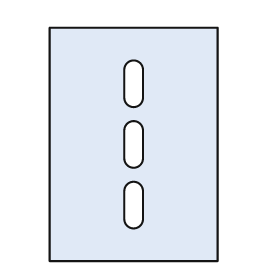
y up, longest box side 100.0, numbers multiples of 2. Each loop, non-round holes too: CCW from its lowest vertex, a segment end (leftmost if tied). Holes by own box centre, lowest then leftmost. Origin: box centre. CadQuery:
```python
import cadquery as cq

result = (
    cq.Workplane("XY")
    .moveTo(-36.0, -50.0)
    .lineTo(36.0, -50.0)
    .lineTo(36.0, 50.0)
    .lineTo(-36.0, 50.0)
    .close()
    .moveTo(-4.0, -32.0)
    .threePointArc((0.0, -36.0), (4.0, -32.0))
    .lineTo(4.0, -20.0)
    .threePointArc((0.0, -16.0), (-4.0, -20.0))
    .close()
    .moveTo(-4.0, -6.0)
    .threePointArc((0.0, -10.0), (4.0, -6.0))
    .lineTo(4.0, 6.0)
    .threePointArc((0.0, 10.0), (-4.0, 6.0))
    .close()
    .moveTo(-4.0, 20.0)
    .threePointArc((0.0, 16.0), (4.0, 20.0))
    .lineTo(4.0, 32.0)
    .threePointArc((0.0, 36.0), (-4.0, 32.0))
    .close()
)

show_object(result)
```